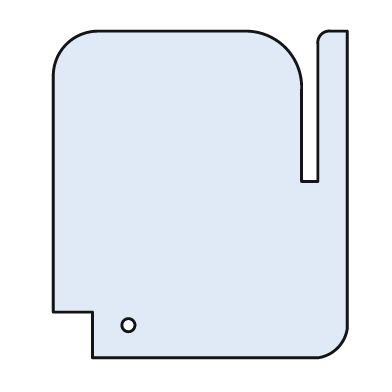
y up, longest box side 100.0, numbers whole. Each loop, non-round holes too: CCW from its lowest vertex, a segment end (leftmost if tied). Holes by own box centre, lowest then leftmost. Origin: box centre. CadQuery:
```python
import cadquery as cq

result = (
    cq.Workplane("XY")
    .moveTo(-33.0, -50.0)
    .lineTo(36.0, -50.0)
    .threePointArc((42.0, -47.0), (45.0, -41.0))
    .lineTo(45.0, 50.0)
    .lineTo(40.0, 50.0)
    .threePointArc((37.0, 49.0), (36.0, 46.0))
    .lineTo(36.0, 4.0)
    .lineTo(31.0, 4.0)
    .lineTo(31.0, 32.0)
    .threePointArc((26.0, 45.0), (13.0, 50.0))
    .lineTo(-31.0, 50.0)
    .threePointArc((-41.0, 46.0), (-45.0, 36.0))
    .lineTo(-45.0, -36.0)
    .lineTo(-33.0, -36.0)
    .close()
    .moveTo(-22.0, -40.0)
    .circle(2.0)
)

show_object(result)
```